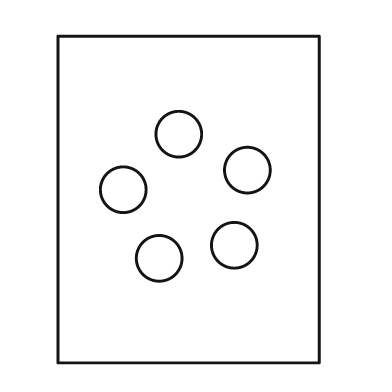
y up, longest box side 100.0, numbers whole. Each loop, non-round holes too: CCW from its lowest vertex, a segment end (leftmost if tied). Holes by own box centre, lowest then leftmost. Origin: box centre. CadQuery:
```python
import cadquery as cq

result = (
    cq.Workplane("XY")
    .moveTo(-40.0, -50.0)
    .lineTo(40.0, -50.0)
    .lineTo(40.0, 50.0)
    .lineTo(-40.0, 50.0)
    .close()
    .moveTo(-9.0, -18.0)
    .circle(7.0)
    .moveTo(14.0, -14.0)
    .circle(7.0)
    .moveTo(-20.0, 3.0)
    .circle(7.0)
    .moveTo(18.0, 9.0)
    .circle(7.0)
    .moveTo(-3.0, 20.0)
    .circle(7.0)
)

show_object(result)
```